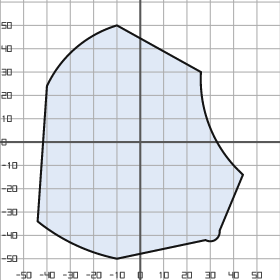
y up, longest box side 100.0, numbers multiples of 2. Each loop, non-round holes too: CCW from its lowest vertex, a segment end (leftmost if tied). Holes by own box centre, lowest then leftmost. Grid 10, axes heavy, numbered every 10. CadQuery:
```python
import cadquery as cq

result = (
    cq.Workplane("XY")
    .moveTo(-10.0, -50.0)
    .lineTo(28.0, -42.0)
    .threePointArc((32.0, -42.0), (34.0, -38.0))
    .lineTo(44.0, -14.0)
    .threePointArc((30.0, 6.0), (26.0, 30.0))
    .lineTo(-10.0, 50.0)
    .threePointArc((-28.0, 40.0), (-40.0, 24.0))
    .lineTo(-44.0, -34.0)
    .threePointArc((-28.0, -44.0), (-10.0, -50.0))
    .close()
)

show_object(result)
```